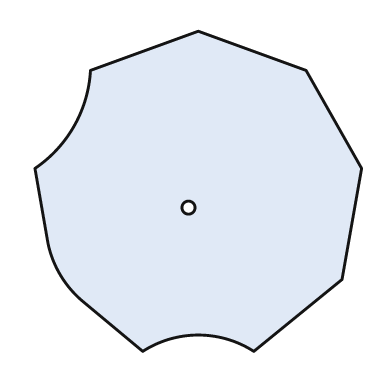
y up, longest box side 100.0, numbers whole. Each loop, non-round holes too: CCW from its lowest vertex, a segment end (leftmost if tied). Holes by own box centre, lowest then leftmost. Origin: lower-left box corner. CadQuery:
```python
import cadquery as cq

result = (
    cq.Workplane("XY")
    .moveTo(33.0, 0.0)
    .threePointArc((50.0, 5.0), (67.0, 0.0))
    .lineTo(94.0, 22.0)
    .lineTo(100.0, 56.0)
    .lineTo(83.0, 86.0)
    .lineTo(50.0, 98.0)
    .lineTo(17.0, 86.0)
    .threePointArc((12.0, 69.0), (0.0, 56.0))
    .lineTo(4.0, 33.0)
    .threePointArc((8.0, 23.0), (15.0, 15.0))
    .close()
    .moveTo(47.0, 44.0)
    .circle(2.0)
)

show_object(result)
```